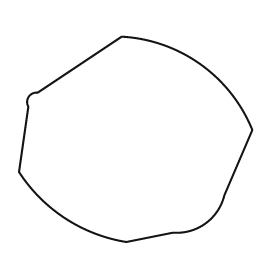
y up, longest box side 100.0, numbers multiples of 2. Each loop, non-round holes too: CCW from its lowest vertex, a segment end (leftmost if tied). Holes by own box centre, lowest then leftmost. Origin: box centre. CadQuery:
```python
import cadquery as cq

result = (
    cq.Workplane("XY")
    .moveTo(-4.0, -44.0)
    .lineTo(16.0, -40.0)
    .threePointArc((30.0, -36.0), (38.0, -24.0))
    .lineTo(50.0, 4.0)
    .threePointArc((28.0, 32.0), (-6.0, 44.0))
    .lineTo(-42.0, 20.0)
    .threePointArc((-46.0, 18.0), (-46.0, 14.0))
    .lineTo(-50.0, -14.0)
    .threePointArc((-30.0, -34.0), (-4.0, -44.0))
    .close()
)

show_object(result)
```